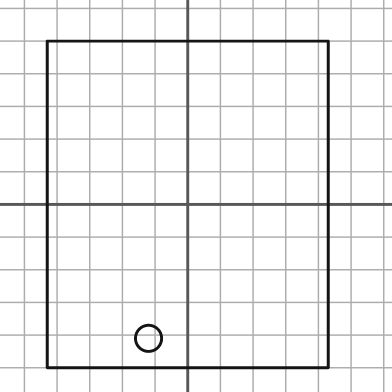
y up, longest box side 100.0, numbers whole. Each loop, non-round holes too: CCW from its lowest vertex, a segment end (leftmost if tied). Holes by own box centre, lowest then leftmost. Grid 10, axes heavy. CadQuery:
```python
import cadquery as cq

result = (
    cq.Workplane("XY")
    .moveTo(-43.0, -50.0)
    .lineTo(43.0, -50.0)
    .lineTo(43.0, 50.0)
    .lineTo(-43.0, 50.0)
    .close()
    .moveTo(-12.0, -41.0)
    .circle(4.0)
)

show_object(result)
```